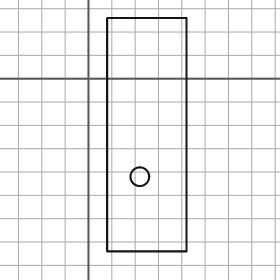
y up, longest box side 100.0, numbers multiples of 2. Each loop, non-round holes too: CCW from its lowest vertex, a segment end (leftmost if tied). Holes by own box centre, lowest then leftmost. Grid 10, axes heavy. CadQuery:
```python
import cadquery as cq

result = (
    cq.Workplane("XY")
    .moveTo(8.0, -74.0)
    .lineTo(42.0, -74.0)
    .lineTo(42.0, 26.0)
    .lineTo(8.0, 26.0)
    .close()
    .moveTo(22.0, -42.0)
    .circle(4.0)
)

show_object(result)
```